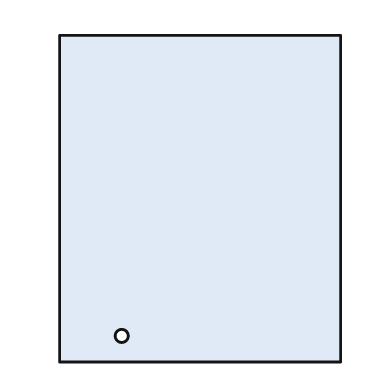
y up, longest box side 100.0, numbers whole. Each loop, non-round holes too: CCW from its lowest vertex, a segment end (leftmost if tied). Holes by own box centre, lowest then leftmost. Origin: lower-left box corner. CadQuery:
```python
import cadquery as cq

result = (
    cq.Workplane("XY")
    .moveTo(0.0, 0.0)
    .lineTo(86.0, 0.0)
    .lineTo(86.0, 100.0)
    .lineTo(0.0, 100.0)
    .close()
    .moveTo(19.0, 8.0)
    .circle(2.0)
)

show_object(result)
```